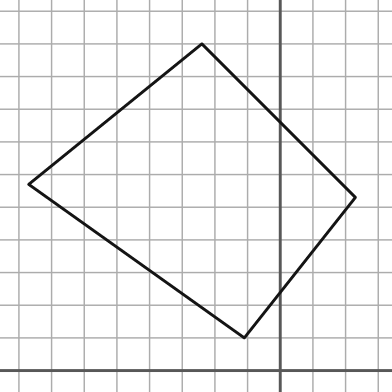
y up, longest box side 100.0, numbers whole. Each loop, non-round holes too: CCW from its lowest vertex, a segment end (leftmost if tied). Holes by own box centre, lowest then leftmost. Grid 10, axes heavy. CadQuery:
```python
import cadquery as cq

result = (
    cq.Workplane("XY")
    .moveTo(-11.0, 10.0)
    .lineTo(23.0, 53.0)
    .lineTo(-24.0, 100.0)
    .lineTo(-77.0, 57.0)
    .close()
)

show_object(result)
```